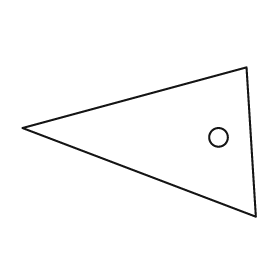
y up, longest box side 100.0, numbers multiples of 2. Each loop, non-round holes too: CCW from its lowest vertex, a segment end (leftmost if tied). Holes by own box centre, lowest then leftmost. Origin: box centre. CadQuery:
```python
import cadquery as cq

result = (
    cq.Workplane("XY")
    .moveTo(50.0, -32.0)
    .lineTo(46.0, 32.0)
    .lineTo(-50.0, 6.0)
    .close()
    .moveTo(34.0, 2.0)
    .circle(4.0)
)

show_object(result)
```